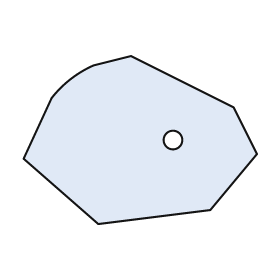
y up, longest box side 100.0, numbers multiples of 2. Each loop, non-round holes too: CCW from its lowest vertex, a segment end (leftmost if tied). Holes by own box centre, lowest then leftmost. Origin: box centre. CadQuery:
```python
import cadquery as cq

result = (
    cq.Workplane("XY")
    .moveTo(-18.0, -36.0)
    .lineTo(30.0, -30.0)
    .lineTo(50.0, -6.0)
    .lineTo(40.0, 14.0)
    .lineTo(-4.0, 36.0)
    .lineTo(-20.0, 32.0)
    .threePointArc((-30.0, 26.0), (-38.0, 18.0))
    .lineTo(-50.0, -8.0)
    .close()
    .moveTo(14.0, 0.0)
    .circle(4.0)
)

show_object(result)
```